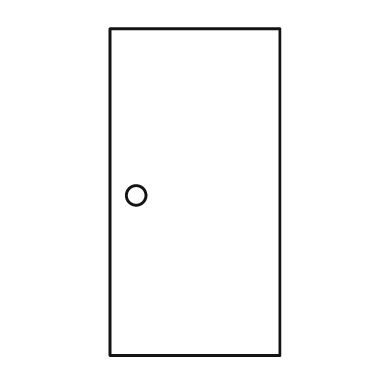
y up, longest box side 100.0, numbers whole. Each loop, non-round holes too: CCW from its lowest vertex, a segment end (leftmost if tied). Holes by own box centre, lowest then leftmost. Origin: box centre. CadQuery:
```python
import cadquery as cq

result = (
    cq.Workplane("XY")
    .moveTo(-26.0, -50.0)
    .lineTo(26.0, -50.0)
    .lineTo(26.0, 50.0)
    .lineTo(-26.0, 50.0)
    .close()
    .moveTo(-18.0, -1.0)
    .circle(3.0)
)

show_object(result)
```